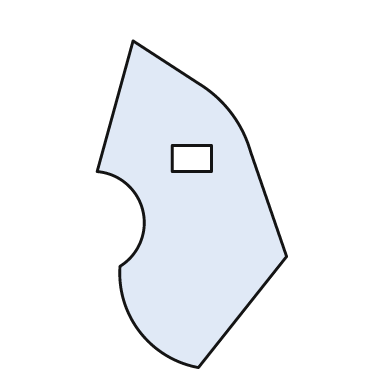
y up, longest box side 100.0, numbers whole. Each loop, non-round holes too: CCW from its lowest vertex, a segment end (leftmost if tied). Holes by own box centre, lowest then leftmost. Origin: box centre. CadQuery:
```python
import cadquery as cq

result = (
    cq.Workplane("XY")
    .moveTo(2.0, -50.0)
    .lineTo(29.0, -16.0)
    .lineTo(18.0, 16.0)
    .threePointArc((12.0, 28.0), (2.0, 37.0))
    .lineTo(-18.0, 50.0)
    .lineTo(-29.0, 10.0)
    .threePointArc((-15.0, -2.0), (-22.0, -19.0))
    .threePointArc((-16.0, -39.0), (2.0, -50.0))
    .close()
    .moveTo(-6.0, 10.0)
    .lineTo(6.0, 10.0)
    .lineTo(6.0, 18.0)
    .lineTo(-6.0, 18.0)
    .close()
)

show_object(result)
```